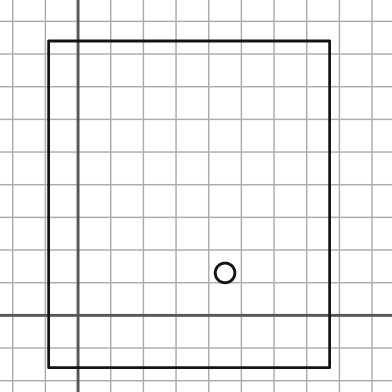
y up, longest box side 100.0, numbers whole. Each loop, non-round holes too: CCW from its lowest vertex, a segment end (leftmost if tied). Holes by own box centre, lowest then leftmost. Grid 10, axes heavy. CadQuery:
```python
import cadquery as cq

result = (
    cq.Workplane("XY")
    .moveTo(-9.0, -16.0)
    .lineTo(77.0, -16.0)
    .lineTo(77.0, 84.0)
    .lineTo(-9.0, 84.0)
    .close()
    .moveTo(45.0, 13.0)
    .circle(3.0)
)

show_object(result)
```